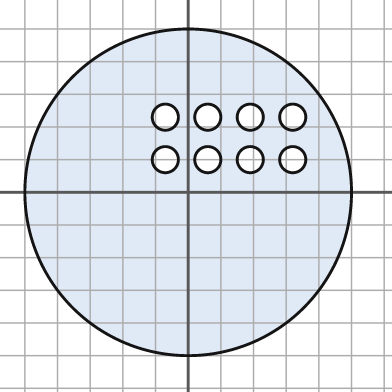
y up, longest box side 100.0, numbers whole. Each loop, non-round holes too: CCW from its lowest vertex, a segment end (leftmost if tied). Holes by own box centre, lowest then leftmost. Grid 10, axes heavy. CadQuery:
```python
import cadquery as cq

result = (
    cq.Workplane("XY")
    .moveTo(0.0, 0.0)
    .circle(50.0)
    .moveTo(-7.0, 10.0)
    .circle(4.0)
    .moveTo(6.0, 10.0)
    .circle(4.0)
    .moveTo(19.0, 10.0)
    .circle(4.0)
    .moveTo(32.0, 10.0)
    .circle(4.0)
    .moveTo(-7.0, 23.0)
    .circle(4.0)
    .moveTo(6.0, 23.0)
    .circle(4.0)
    .moveTo(19.0, 23.0)
    .circle(4.0)
    .moveTo(32.0, 23.0)
    .circle(4.0)
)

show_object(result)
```